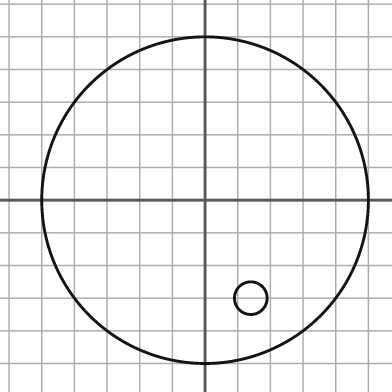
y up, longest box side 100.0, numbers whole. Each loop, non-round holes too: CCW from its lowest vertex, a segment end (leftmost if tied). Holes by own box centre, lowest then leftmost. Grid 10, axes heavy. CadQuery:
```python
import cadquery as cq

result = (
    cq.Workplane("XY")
    .moveTo(0.0, 0.0)
    .circle(50.0)
    .moveTo(14.0, -30.0)
    .circle(5.0)
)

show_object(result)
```